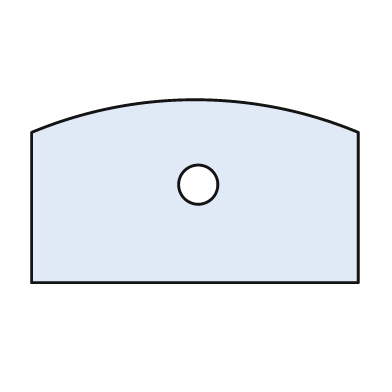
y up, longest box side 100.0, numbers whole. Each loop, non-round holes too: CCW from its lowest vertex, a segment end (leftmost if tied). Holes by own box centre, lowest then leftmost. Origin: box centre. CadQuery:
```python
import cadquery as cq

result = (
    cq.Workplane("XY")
    .moveTo(-50.0, -28.0)
    .lineTo(50.0, -28.0)
    .lineTo(50.0, 18.0)
    .threePointArc((0.0, 28.0), (-50.0, 18.0))
    .close()
    .moveTo(1.0, 2.0)
    .circle(6.0)
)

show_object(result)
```